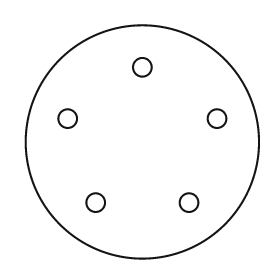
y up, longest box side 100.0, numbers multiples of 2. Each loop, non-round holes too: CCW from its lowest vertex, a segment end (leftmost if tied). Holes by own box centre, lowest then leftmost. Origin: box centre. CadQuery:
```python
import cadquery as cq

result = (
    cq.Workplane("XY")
    .moveTo(0.0, 0.0)
    .circle(50.0)
    .moveTo(-20.0, -26.0)
    .circle(4.0)
    .moveTo(20.0, -26.0)
    .circle(4.0)
    .moveTo(-32.0, 10.0)
    .circle(4.0)
    .moveTo(32.0, 10.0)
    .circle(4.0)
    .moveTo(0.0, 32.0)
    .circle(4.0)
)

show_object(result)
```